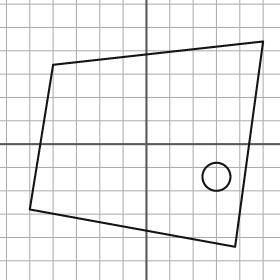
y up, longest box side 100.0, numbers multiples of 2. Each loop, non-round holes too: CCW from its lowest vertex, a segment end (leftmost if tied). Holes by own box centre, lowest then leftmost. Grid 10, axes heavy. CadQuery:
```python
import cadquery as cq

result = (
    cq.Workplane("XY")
    .moveTo(38.0, -44.0)
    .lineTo(50.0, 44.0)
    .lineTo(-40.0, 34.0)
    .lineTo(-50.0, -28.0)
    .close()
    .moveTo(30.0, -14.0)
    .circle(6.0)
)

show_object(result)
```